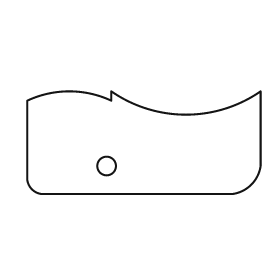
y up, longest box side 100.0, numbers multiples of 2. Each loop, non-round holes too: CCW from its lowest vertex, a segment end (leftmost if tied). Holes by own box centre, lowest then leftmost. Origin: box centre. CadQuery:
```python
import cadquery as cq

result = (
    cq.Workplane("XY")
    .moveTo(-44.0, -22.0)
    .lineTo(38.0, -22.0)
    .threePointArc((46.0, -18.0), (50.0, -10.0))
    .lineTo(50.0, 22.0)
    .threePointArc((18.0, 12.0), (-14.0, 22.0))
    .lineTo(-14.0, 18.0)
    .threePointArc((-32.0, 22.0), (-50.0, 18.0))
    .lineTo(-50.0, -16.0)
    .threePointArc((-48.0, -20.0), (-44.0, -22.0))
    .close()
    .moveTo(-16.0, -10.0)
    .circle(4.0)
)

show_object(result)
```